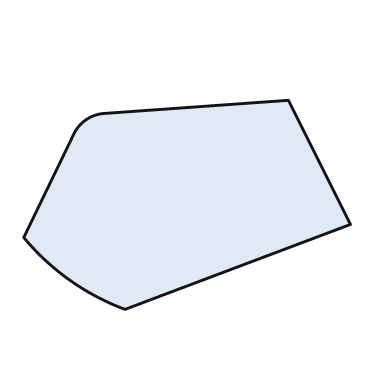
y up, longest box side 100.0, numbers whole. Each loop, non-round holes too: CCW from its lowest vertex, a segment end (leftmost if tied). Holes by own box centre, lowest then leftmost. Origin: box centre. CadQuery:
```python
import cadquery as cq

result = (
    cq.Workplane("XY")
    .moveTo(-19.0, -32.0)
    .lineTo(50.0, -6.0)
    .lineTo(31.0, 32.0)
    .lineTo(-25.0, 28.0)
    .threePointArc((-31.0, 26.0), (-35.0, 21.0))
    .lineTo(-50.0, -10.0)
    .threePointArc((-36.0, -23.0), (-19.0, -32.0))
    .close()
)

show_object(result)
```